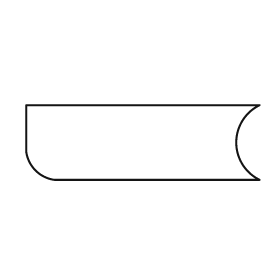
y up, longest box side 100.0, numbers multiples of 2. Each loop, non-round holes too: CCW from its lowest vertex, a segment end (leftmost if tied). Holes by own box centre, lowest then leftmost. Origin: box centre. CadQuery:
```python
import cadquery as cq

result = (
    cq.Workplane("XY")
    .moveTo(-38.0, -16.0)
    .lineTo(50.0, -16.0)
    .threePointArc((40.0, 0.0), (50.0, 16.0))
    .lineTo(-50.0, 16.0)
    .lineTo(-50.0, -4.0)
    .threePointArc((-46.0, -12.0), (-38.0, -16.0))
    .close()
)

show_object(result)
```